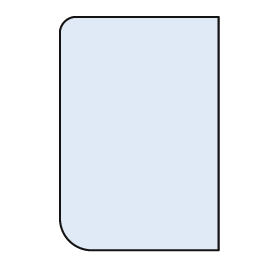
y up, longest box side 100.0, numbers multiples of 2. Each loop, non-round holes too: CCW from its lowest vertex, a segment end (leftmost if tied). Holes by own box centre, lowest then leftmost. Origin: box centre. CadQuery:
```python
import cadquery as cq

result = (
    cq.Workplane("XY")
    .moveTo(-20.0, -50.0)
    .lineTo(34.0, -50.0)
    .lineTo(34.0, 50.0)
    .lineTo(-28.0, 50.0)
    .threePointArc((-32.0, 48.0), (-34.0, 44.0))
    .lineTo(-34.0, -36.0)
    .threePointArc((-30.0, -46.0), (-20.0, -50.0))
    .close()
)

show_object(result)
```